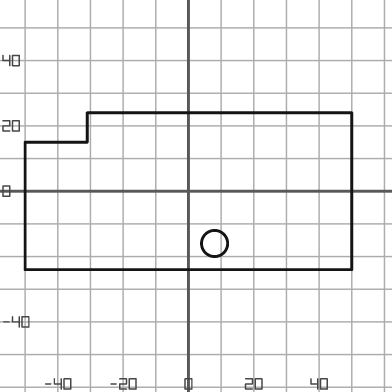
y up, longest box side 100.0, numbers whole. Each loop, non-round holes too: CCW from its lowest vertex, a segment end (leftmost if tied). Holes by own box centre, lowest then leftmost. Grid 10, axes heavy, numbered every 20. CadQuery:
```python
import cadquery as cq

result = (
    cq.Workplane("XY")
    .moveTo(-50.0, -24.0)
    .lineTo(50.0, -24.0)
    .lineTo(50.0, 24.0)
    .lineTo(-31.0, 24.0)
    .lineTo(-31.0, 15.0)
    .lineTo(-50.0, 15.0)
    .close()
    .moveTo(8.0, -16.0)
    .circle(4.0)
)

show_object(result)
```